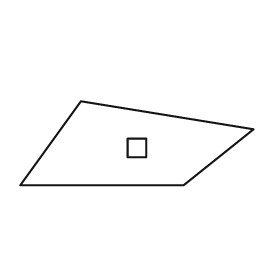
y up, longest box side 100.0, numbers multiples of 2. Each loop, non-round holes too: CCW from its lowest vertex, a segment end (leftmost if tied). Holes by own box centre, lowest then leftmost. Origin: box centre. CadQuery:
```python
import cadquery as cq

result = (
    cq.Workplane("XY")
    .moveTo(-50.0, -18.0)
    .lineTo(20.0, -18.0)
    .lineTo(50.0, 6.0)
    .lineTo(-24.0, 18.0)
    .close()
    .moveTo(-4.0, -6.0)
    .lineTo(4.0, -6.0)
    .lineTo(4.0, 2.0)
    .lineTo(-4.0, 2.0)
    .close()
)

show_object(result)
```